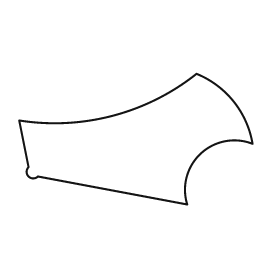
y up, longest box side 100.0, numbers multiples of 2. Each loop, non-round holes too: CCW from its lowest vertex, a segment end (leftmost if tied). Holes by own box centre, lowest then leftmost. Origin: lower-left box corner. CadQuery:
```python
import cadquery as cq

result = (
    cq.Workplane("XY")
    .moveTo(72.0, 0.0)
    .threePointArc((78.0, 22.0), (100.0, 26.0))
    .threePointArc((92.0, 44.0), (76.0, 56.0))
    .threePointArc((40.0, 38.0), (0.0, 36.0))
    .lineTo(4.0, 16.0)
    .threePointArc((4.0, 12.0), (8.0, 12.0))
    .close()
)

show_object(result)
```